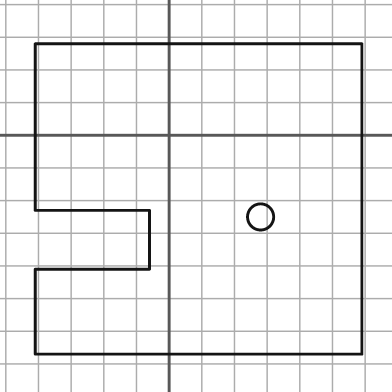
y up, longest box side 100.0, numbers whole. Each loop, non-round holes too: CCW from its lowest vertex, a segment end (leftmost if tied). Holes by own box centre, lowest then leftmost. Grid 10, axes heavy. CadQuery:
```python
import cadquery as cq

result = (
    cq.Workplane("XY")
    .moveTo(-41.0, -67.0)
    .lineTo(59.0, -67.0)
    .lineTo(59.0, 28.0)
    .lineTo(-41.0, 28.0)
    .lineTo(-41.0, -23.0)
    .lineTo(-6.0, -23.0)
    .lineTo(-6.0, -41.0)
    .lineTo(-41.0, -41.0)
    .close()
    .moveTo(28.0, -25.0)
    .circle(4.0)
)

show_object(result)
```